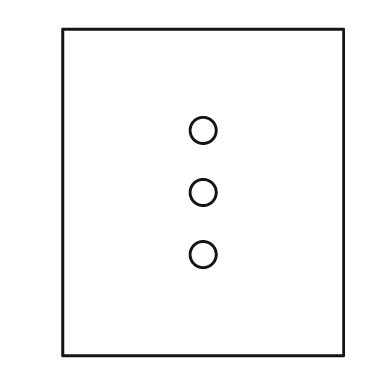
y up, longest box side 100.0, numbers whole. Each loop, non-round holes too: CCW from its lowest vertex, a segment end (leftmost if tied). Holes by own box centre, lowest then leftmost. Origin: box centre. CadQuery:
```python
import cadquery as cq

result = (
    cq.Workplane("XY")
    .moveTo(-43.0, -50.0)
    .lineTo(43.0, -50.0)
    .lineTo(43.0, 50.0)
    .lineTo(-43.0, 50.0)
    .close()
    .moveTo(0.0, -19.0)
    .circle(4.0)
    .moveTo(0.0, 0.0)
    .circle(4.0)
    .moveTo(0.0, 19.0)
    .circle(4.0)
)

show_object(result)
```